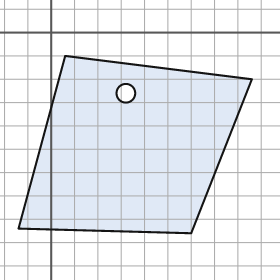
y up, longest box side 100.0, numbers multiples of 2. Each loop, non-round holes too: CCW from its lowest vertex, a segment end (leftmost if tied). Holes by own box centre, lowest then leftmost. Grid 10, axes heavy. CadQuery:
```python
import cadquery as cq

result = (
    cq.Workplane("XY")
    .moveTo(60.0, -86.0)
    .lineTo(86.0, -20.0)
    .lineTo(6.0, -10.0)
    .lineTo(-14.0, -84.0)
    .close()
    .moveTo(32.0, -26.0)
    .circle(4.0)
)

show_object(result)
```